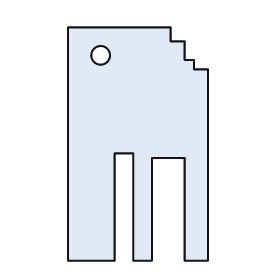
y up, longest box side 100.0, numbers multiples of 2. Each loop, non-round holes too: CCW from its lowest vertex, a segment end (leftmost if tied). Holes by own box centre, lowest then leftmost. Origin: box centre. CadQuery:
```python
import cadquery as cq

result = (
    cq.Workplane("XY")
    .moveTo(-30.0, -50.0)
    .lineTo(-10.0, -50.0)
    .lineTo(-10.0, -4.0)
    .lineTo(-2.0, -4.0)
    .lineTo(-2.0, -50.0)
    .lineTo(6.0, -50.0)
    .lineTo(6.0, -6.0)
    .lineTo(20.0, -6.0)
    .lineTo(20.0, -50.0)
    .lineTo(30.0, -50.0)
    .lineTo(30.0, 32.0)
    .lineTo(24.0, 32.0)
    .lineTo(24.0, 36.0)
    .lineTo(20.0, 36.0)
    .lineTo(20.0, 44.0)
    .lineTo(14.0, 44.0)
    .lineTo(14.0, 50.0)
    .lineTo(-30.0, 50.0)
    .close()
    .moveTo(-16.0, 38.0)
    .circle(4.0)
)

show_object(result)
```